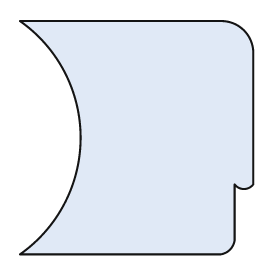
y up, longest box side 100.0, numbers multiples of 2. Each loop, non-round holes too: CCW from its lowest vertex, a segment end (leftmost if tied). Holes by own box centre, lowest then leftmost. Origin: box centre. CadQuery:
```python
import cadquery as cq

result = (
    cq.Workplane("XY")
    .moveTo(-50.0, -50.0)
    .lineTo(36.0, -50.0)
    .threePointArc((40.0, -48.0), (42.0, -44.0))
    .lineTo(42.0, -20.0)
    .threePointArc((46.0, -22.0), (50.0, -20.0))
    .lineTo(50.0, 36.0)
    .threePointArc((46.0, 46.0), (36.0, 50.0))
    .lineTo(-50.0, 50.0)
    .threePointArc((-24.0, 0.0), (-50.0, -50.0))
    .close()
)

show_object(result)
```